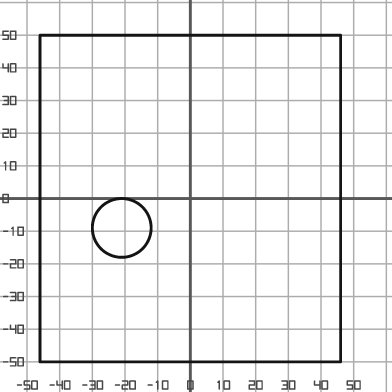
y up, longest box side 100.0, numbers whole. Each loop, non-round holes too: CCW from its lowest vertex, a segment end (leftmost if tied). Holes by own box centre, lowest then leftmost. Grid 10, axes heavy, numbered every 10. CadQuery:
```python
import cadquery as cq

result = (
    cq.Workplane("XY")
    .moveTo(-46.0, -50.0)
    .lineTo(46.0, -50.0)
    .lineTo(46.0, 50.0)
    .lineTo(-46.0, 50.0)
    .close()
    .moveTo(-21.0, -9.0)
    .circle(9.0)
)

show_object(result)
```